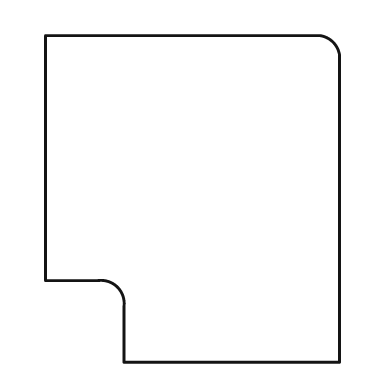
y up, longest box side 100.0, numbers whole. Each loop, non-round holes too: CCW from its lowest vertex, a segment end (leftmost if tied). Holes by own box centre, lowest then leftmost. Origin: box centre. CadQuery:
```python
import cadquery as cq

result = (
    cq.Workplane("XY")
    .moveTo(-21.0, -50.0)
    .lineTo(45.0, -50.0)
    .lineTo(45.0, 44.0)
    .threePointArc((43.0, 48.0), (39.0, 50.0))
    .lineTo(-45.0, 50.0)
    .lineTo(-45.0, -25.0)
    .lineTo(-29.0, -25.0)
    .threePointArc((-23.0, -27.0), (-21.0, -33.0))
    .close()
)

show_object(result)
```